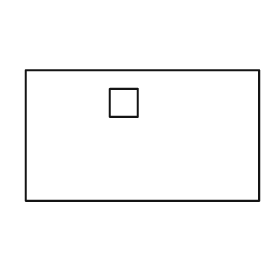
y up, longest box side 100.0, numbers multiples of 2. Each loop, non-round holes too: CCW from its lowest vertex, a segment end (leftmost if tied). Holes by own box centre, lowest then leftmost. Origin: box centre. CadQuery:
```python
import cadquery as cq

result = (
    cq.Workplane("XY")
    .moveTo(-50.0, -28.0)
    .lineTo(50.0, -28.0)
    .lineTo(50.0, 28.0)
    .lineTo(-50.0, 28.0)
    .close()
    .moveTo(-14.0, 8.0)
    .lineTo(-2.0, 8.0)
    .lineTo(-2.0, 20.0)
    .lineTo(-14.0, 20.0)
    .close()
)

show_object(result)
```